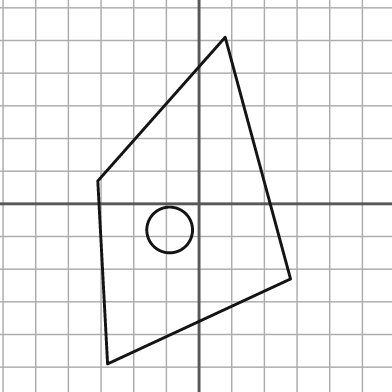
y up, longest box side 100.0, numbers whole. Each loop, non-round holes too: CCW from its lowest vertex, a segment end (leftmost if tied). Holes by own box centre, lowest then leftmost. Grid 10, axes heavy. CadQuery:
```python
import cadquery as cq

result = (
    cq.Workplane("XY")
    .moveTo(-28.0, -49.0)
    .lineTo(28.0, -23.0)
    .lineTo(8.0, 51.0)
    .lineTo(-31.0, 7.0)
    .close()
    .moveTo(-9.0, -8.0)
    .circle(7.0)
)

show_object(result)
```